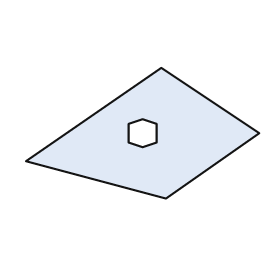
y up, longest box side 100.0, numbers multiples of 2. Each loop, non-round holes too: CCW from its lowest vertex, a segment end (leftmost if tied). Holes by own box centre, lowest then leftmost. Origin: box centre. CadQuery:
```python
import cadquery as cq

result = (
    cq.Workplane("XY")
    .moveTo(10.0, -28.0)
    .lineTo(50.0, 0.0)
    .lineTo(8.0, 28.0)
    .lineTo(-50.0, -12.0)
    .close()
    .moveTo(0.0, -6.0)
    .lineTo(6.0, -4.0)
    .lineTo(6.0, 4.0)
    .lineTo(0.0, 6.0)
    .lineTo(-6.0, 4.0)
    .lineTo(-6.0, -4.0)
    .close()
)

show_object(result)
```